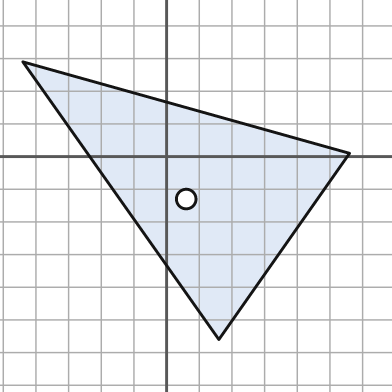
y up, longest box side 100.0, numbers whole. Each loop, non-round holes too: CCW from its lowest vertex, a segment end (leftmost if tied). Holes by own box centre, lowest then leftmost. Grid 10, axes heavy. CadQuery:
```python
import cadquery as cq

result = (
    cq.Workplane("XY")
    .moveTo(16.0, -56.0)
    .lineTo(56.0, 1.0)
    .lineTo(-44.0, 29.0)
    .close()
    .moveTo(6.0, -13.0)
    .circle(3.0)
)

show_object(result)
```